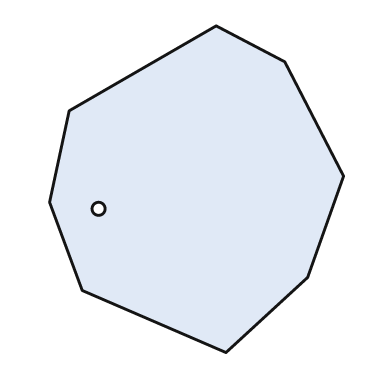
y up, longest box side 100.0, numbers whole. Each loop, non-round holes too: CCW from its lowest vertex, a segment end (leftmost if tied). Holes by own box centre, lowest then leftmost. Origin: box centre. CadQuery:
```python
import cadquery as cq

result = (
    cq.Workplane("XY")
    .moveTo(9.0, -50.0)
    .lineTo(34.0, -27.0)
    .lineTo(45.0, 4.0)
    .lineTo(27.0, 39.0)
    .lineTo(6.0, 50.0)
    .lineTo(-39.0, 24.0)
    .lineTo(-45.0, -4.0)
    .lineTo(-35.0, -31.0)
    .close()
    .moveTo(-30.0, -6.0)
    .circle(2.0)
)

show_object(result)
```